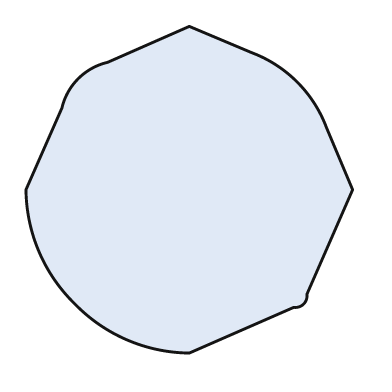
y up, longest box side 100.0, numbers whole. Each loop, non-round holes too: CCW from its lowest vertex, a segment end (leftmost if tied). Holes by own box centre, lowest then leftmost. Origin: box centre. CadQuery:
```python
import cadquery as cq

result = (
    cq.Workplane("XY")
    .moveTo(0.0, -50.0)
    .lineTo(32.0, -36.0)
    .threePointArc((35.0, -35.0), (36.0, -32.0))
    .lineTo(50.0, 0.0)
    .lineTo(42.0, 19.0)
    .threePointArc((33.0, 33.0), (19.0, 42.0))
    .lineTo(0.0, 50.0)
    .lineTo(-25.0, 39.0)
    .threePointArc((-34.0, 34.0), (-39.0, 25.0))
    .lineTo(-50.0, 0.0)
    .threePointArc((-46.0, -19.0), (-35.0, -35.0))
    .threePointArc((-19.0, -46.0), (0.0, -50.0))
    .close()
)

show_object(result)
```